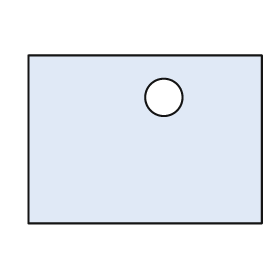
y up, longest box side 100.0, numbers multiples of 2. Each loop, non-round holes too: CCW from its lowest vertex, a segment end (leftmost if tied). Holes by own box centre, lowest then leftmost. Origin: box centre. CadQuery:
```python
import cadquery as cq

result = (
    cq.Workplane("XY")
    .moveTo(-50.0, -36.0)
    .lineTo(50.0, -36.0)
    .lineTo(50.0, 36.0)
    .lineTo(-50.0, 36.0)
    .close()
    .moveTo(8.0, 18.0)
    .circle(8.0)
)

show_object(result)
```